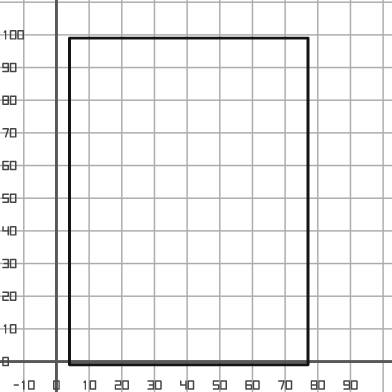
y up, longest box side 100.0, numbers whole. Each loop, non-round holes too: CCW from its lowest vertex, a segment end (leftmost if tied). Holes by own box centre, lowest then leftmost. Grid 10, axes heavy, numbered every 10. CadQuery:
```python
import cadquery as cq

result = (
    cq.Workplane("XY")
    .moveTo(4.0, -1.0)
    .lineTo(77.0, -1.0)
    .lineTo(77.0, 99.0)
    .lineTo(4.0, 99.0)
    .close()
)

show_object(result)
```